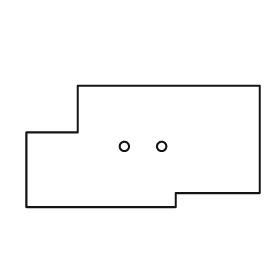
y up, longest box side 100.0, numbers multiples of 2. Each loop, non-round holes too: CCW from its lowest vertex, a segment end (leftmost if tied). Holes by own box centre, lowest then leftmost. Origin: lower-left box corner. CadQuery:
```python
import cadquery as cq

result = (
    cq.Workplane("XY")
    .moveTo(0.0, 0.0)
    .lineTo(64.0, 0.0)
    .lineTo(64.0, 6.0)
    .lineTo(100.0, 6.0)
    .lineTo(100.0, 52.0)
    .lineTo(22.0, 52.0)
    .lineTo(22.0, 32.0)
    .lineTo(0.0, 32.0)
    .close()
    .moveTo(42.0, 26.0)
    .circle(2.0)
    .moveTo(58.0, 26.0)
    .circle(2.0)
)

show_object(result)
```